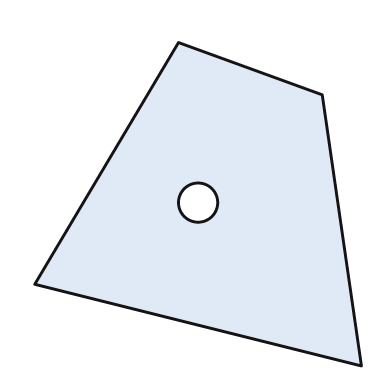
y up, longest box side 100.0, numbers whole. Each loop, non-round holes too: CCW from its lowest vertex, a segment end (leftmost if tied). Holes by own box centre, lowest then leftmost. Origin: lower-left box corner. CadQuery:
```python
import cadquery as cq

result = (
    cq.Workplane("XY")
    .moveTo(100.0, 0.0)
    .lineTo(88.0, 83.0)
    .lineTo(44.0, 99.0)
    .lineTo(0.0, 25.0)
    .close()
    .moveTo(50.0, 50.0)
    .circle(6.0)
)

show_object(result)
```